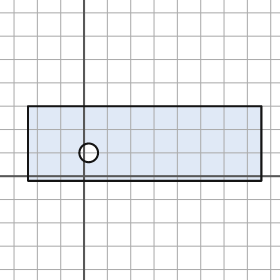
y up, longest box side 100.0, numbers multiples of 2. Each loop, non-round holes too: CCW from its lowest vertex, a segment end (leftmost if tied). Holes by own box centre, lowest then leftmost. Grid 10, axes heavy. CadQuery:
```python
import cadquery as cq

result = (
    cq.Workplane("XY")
    .moveTo(-24.0, -2.0)
    .lineTo(76.0, -2.0)
    .lineTo(76.0, 30.0)
    .lineTo(-24.0, 30.0)
    .close()
    .moveTo(2.0, 10.0)
    .circle(4.0)
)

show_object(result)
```